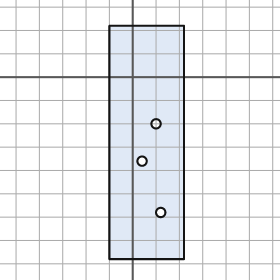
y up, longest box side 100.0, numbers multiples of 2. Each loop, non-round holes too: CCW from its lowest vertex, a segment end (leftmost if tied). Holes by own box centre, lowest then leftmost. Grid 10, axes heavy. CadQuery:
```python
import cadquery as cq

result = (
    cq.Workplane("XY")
    .moveTo(-10.0, -78.0)
    .lineTo(22.0, -78.0)
    .lineTo(22.0, 22.0)
    .lineTo(-10.0, 22.0)
    .close()
    .moveTo(12.0, -58.0)
    .circle(2.0)
    .moveTo(4.0, -36.0)
    .circle(2.0)
    .moveTo(10.0, -20.0)
    .circle(2.0)
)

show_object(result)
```